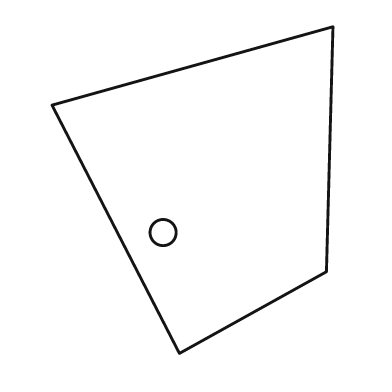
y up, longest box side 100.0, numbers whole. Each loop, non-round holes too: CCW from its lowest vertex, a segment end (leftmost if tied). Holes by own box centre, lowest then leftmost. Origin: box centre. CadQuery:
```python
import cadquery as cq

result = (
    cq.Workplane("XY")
    .moveTo(-4.0, -50.0)
    .lineTo(41.0, -25.0)
    .lineTo(43.0, 50.0)
    .lineTo(-43.0, 26.0)
    .close()
    .moveTo(-9.0, -13.0)
    .circle(4.0)
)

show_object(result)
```